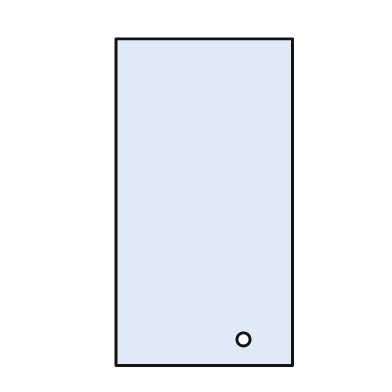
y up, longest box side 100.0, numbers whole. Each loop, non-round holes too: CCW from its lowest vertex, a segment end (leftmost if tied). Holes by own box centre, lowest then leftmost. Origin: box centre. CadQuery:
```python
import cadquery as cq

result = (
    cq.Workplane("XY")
    .moveTo(-27.0, -50.0)
    .lineTo(27.0, -50.0)
    .lineTo(27.0, 50.0)
    .lineTo(-27.0, 50.0)
    .close()
    .moveTo(12.0, -42.0)
    .circle(2.0)
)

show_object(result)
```